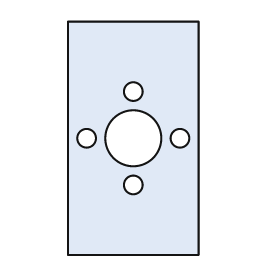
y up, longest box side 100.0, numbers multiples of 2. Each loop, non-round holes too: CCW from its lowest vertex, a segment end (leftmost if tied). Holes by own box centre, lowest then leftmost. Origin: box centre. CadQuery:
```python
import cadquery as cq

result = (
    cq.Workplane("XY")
    .moveTo(-28.0, -50.0)
    .lineTo(28.0, -50.0)
    .lineTo(28.0, 50.0)
    .lineTo(-28.0, 50.0)
    .close()
    .moveTo(0.0, -20.0)
    .circle(4.0)
    .moveTo(-20.0, 0.0)
    .circle(4.0)
    .moveTo(0.0, 0.0)
    .circle(12.0)
    .moveTo(20.0, 0.0)
    .circle(4.0)
    .moveTo(0.0, 20.0)
    .circle(4.0)
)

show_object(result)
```